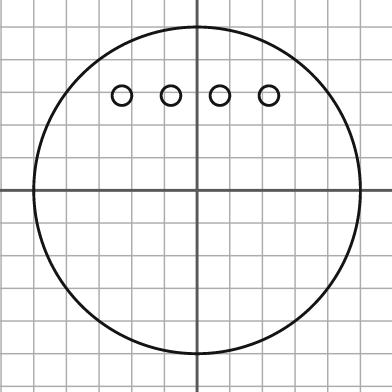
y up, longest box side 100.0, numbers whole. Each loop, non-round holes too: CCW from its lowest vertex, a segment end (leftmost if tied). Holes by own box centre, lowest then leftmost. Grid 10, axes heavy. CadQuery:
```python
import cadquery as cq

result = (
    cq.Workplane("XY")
    .moveTo(0.0, 0.0)
    .circle(50.0)
    .moveTo(-23.0, 29.0)
    .circle(3.0)
    .moveTo(-8.0, 29.0)
    .circle(3.0)
    .moveTo(7.0, 29.0)
    .circle(3.0)
    .moveTo(22.0, 29.0)
    .circle(3.0)
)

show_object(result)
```